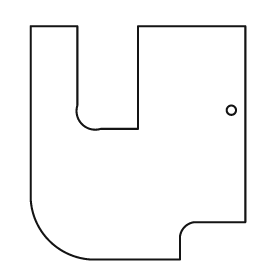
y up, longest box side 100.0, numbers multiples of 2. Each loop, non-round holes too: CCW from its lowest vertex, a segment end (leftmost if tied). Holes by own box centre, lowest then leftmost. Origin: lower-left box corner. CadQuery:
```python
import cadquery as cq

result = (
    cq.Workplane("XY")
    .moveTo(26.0, 0.0)
    .lineTo(64.0, 0.0)
    .lineTo(64.0, 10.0)
    .threePointArc((66.0, 14.0), (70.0, 16.0))
    .lineTo(92.0, 16.0)
    .lineTo(92.0, 100.0)
    .lineTo(46.0, 100.0)
    .lineTo(46.0, 56.0)
    .lineTo(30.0, 56.0)
    .threePointArc((22.0, 58.0), (20.0, 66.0))
    .lineTo(20.0, 100.0)
    .lineTo(0.0, 100.0)
    .lineTo(0.0, 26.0)
    .threePointArc((8.0, 8.0), (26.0, 0.0))
    .close()
    .moveTo(86.0, 64.0)
    .circle(2.0)
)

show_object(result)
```